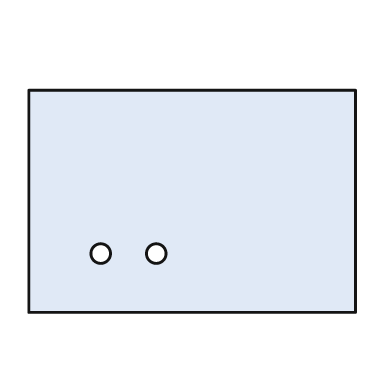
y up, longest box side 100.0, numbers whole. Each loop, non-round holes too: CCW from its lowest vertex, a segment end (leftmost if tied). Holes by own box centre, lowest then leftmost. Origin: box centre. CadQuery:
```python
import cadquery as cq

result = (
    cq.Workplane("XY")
    .moveTo(-50.0, -34.0)
    .lineTo(50.0, -34.0)
    .lineTo(50.0, 34.0)
    .lineTo(-50.0, 34.0)
    .close()
    .moveTo(-28.0, -16.0)
    .circle(3.0)
    .moveTo(-11.0, -16.0)
    .circle(3.0)
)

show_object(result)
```